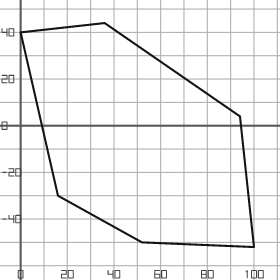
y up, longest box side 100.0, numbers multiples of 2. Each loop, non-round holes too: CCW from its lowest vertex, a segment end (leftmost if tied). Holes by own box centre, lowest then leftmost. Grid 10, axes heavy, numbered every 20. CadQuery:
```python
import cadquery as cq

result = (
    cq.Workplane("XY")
    .moveTo(100.0, -52.0)
    .lineTo(94.0, 4.0)
    .lineTo(36.0, 44.0)
    .lineTo(0.0, 40.0)
    .lineTo(16.0, -30.0)
    .lineTo(52.0, -50.0)
    .close()
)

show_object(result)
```